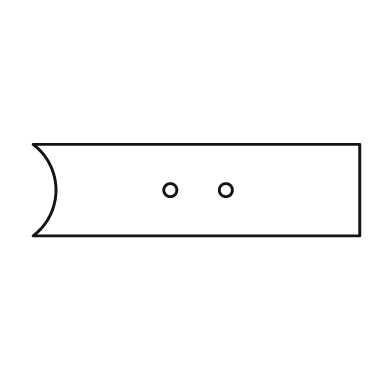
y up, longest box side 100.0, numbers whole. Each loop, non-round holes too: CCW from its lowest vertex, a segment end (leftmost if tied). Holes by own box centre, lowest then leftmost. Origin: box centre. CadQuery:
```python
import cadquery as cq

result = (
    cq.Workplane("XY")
    .moveTo(-50.0, -14.0)
    .lineTo(50.0, -14.0)
    .lineTo(50.0, 14.0)
    .lineTo(-50.0, 14.0)
    .threePointArc((-43.0, 0.0), (-50.0, -14.0))
    .close()
    .moveTo(-8.0, 0.0)
    .circle(2.0)
    .moveTo(9.0, 0.0)
    .circle(2.0)
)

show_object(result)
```